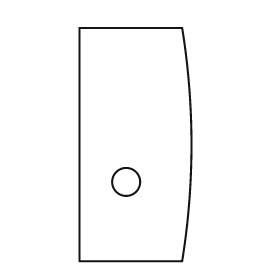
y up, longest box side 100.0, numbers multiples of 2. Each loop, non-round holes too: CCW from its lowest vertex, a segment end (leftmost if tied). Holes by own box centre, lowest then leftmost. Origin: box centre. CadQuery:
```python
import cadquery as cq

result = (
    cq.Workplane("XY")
    .moveTo(-24.0, -50.0)
    .lineTo(20.0, -50.0)
    .threePointArc((24.0, 0.0), (20.0, 50.0))
    .lineTo(-24.0, 50.0)
    .close()
    .moveTo(-4.0, -16.0)
    .circle(6.0)
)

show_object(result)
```